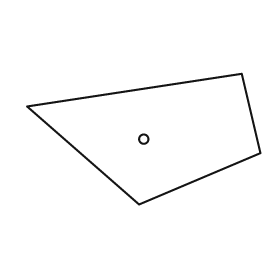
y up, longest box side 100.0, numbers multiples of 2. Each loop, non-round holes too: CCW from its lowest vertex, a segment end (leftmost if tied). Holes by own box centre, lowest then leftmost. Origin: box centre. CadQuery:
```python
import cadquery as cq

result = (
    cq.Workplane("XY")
    .moveTo(-2.0, -28.0)
    .lineTo(50.0, -6.0)
    .lineTo(42.0, 28.0)
    .lineTo(-50.0, 14.0)
    .close()
    .moveTo(0.0, 0.0)
    .circle(2.0)
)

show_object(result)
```